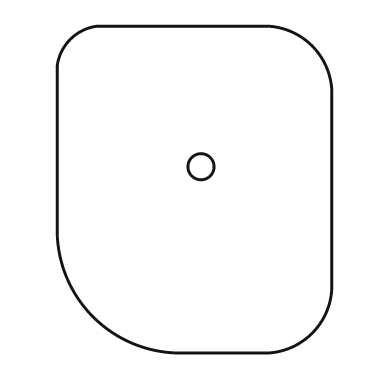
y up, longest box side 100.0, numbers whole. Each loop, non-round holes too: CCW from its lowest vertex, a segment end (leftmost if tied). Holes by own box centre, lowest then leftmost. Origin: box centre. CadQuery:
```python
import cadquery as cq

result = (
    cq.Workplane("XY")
    .moveTo(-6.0, -50.0)
    .lineTo(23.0, -50.0)
    .threePointArc((36.0, -44.0), (42.0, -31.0))
    .lineTo(42.0, 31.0)
    .threePointArc((36.0, 44.0), (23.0, 50.0))
    .lineTo(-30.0, 50.0)
    .threePointArc((-38.0, 46.0), (-42.0, 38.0))
    .lineTo(-42.0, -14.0)
    .threePointArc((-31.0, -39.0), (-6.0, -50.0))
    .close()
    .moveTo(2.0, 7.0)
    .circle(4.0)
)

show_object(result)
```